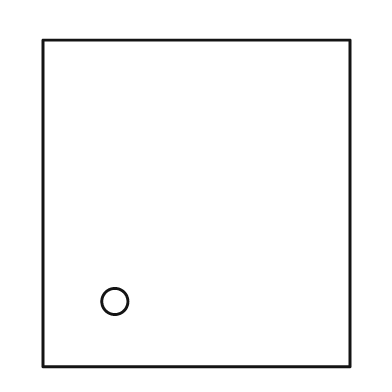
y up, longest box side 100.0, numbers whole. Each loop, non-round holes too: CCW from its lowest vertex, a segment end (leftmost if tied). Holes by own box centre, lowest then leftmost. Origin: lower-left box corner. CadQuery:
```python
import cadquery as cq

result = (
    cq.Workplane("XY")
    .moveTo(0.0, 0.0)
    .lineTo(94.0, 0.0)
    .lineTo(94.0, 100.0)
    .lineTo(0.0, 100.0)
    .close()
    .moveTo(22.0, 20.0)
    .circle(4.0)
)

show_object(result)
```